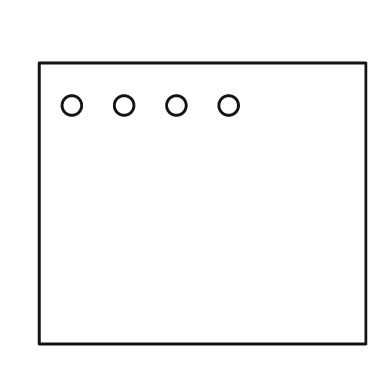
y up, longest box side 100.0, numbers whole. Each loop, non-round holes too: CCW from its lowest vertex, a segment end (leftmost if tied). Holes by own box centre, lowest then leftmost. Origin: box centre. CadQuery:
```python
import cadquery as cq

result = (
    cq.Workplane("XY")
    .moveTo(-50.0, -43.0)
    .lineTo(50.0, -43.0)
    .lineTo(50.0, 43.0)
    .lineTo(-50.0, 43.0)
    .close()
    .moveTo(-40.0, 30.0)
    .circle(3.0)
    .moveTo(-24.0, 30.0)
    .circle(3.0)
    .moveTo(-8.0, 30.0)
    .circle(3.0)
    .moveTo(8.0, 30.0)
    .circle(3.0)
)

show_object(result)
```